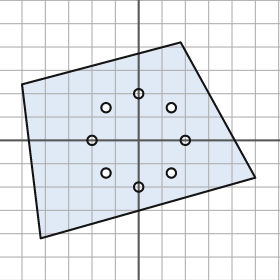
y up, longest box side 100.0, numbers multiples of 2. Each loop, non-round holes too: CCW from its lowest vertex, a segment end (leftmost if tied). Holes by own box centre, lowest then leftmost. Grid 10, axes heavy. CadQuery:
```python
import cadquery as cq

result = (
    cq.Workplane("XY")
    .moveTo(-42.0, -42.0)
    .lineTo(50.0, -16.0)
    .lineTo(18.0, 42.0)
    .lineTo(-50.0, 24.0)
    .close()
    .moveTo(0.0, -20.0)
    .circle(2.0)
    .moveTo(-14.0, -14.0)
    .circle(2.0)
    .moveTo(14.0, -14.0)
    .circle(2.0)
    .moveTo(-20.0, 0.0)
    .circle(2.0)
    .moveTo(20.0, 0.0)
    .circle(2.0)
    .moveTo(-14.0, 14.0)
    .circle(2.0)
    .moveTo(14.0, 14.0)
    .circle(2.0)
    .moveTo(0.0, 20.0)
    .circle(2.0)
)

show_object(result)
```